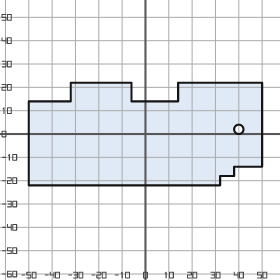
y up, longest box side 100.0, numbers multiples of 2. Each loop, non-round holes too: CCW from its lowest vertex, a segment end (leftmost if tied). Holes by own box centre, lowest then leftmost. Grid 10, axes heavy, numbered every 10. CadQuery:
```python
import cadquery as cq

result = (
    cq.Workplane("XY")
    .moveTo(-50.0, -22.0)
    .lineTo(32.0, -22.0)
    .lineTo(32.0, -18.0)
    .lineTo(38.0, -18.0)
    .lineTo(38.0, -14.0)
    .lineTo(50.0, -14.0)
    .lineTo(50.0, 22.0)
    .lineTo(14.0, 22.0)
    .lineTo(14.0, 14.0)
    .lineTo(-6.0, 14.0)
    .lineTo(-6.0, 22.0)
    .lineTo(-32.0, 22.0)
    .lineTo(-32.0, 14.0)
    .lineTo(-50.0, 14.0)
    .close()
    .moveTo(40.0, 2.0)
    .circle(2.0)
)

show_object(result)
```